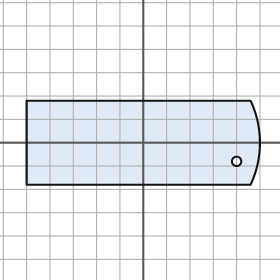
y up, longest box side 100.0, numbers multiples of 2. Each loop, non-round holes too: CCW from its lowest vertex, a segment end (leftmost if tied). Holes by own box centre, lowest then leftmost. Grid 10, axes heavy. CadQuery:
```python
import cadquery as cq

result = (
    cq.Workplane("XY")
    .moveTo(-50.0, -18.0)
    .lineTo(46.0, -18.0)
    .threePointArc((50.0, 0.0), (46.0, 18.0))
    .lineTo(-50.0, 18.0)
    .close()
    .moveTo(40.0, -8.0)
    .circle(2.0)
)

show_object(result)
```